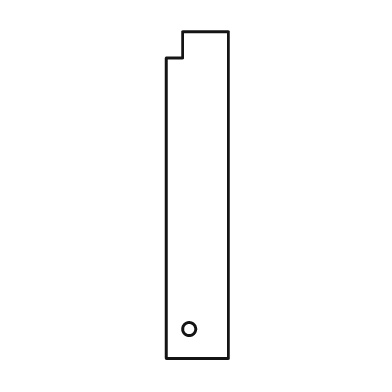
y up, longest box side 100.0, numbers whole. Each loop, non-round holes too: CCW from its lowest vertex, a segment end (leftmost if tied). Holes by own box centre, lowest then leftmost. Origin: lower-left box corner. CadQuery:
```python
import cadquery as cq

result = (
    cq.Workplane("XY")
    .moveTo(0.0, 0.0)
    .lineTo(19.0, 0.0)
    .lineTo(19.0, 100.0)
    .lineTo(5.0, 100.0)
    .lineTo(5.0, 92.0)
    .lineTo(0.0, 92.0)
    .close()
    .moveTo(7.0, 9.0)
    .circle(2.0)
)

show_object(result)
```